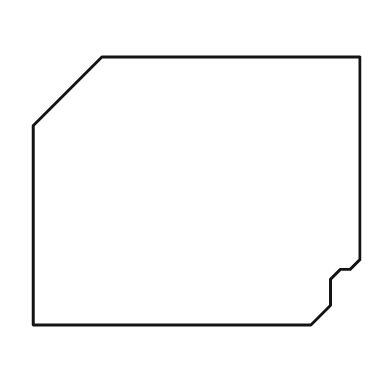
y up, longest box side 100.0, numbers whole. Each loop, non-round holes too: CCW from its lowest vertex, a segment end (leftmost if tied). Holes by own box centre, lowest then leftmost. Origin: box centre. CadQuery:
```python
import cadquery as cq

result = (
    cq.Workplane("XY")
    .moveTo(-50.0, -41.0)
    .lineTo(35.0, -41.0)
    .lineTo(41.0, -35.0)
    .lineTo(41.0, -27.0)
    .lineTo(44.0, -24.0)
    .lineTo(47.0, -24.0)
    .lineTo(50.0, -21.0)
    .lineTo(50.0, 41.0)
    .lineTo(-29.0, 41.0)
    .lineTo(-50.0, 20.0)
    .close()
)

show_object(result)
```